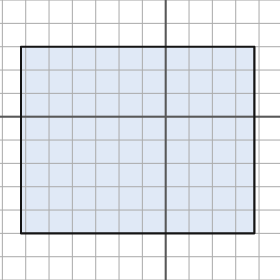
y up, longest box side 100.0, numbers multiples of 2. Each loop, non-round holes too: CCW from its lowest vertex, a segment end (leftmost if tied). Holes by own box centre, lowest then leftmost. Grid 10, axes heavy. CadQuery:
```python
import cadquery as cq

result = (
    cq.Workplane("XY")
    .moveTo(-62.0, -50.0)
    .lineTo(38.0, -50.0)
    .lineTo(38.0, 30.0)
    .lineTo(-62.0, 30.0)
    .close()
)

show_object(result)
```